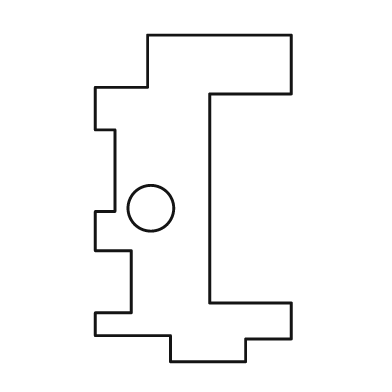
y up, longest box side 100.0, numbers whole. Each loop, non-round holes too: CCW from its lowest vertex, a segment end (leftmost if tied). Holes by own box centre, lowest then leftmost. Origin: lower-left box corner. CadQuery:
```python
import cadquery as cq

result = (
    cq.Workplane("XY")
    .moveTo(23.0, 0.0)
    .lineTo(46.0, 0.0)
    .lineTo(46.0, 7.0)
    .lineTo(60.0, 7.0)
    .lineTo(60.0, 18.0)
    .lineTo(35.0, 18.0)
    .lineTo(35.0, 82.0)
    .lineTo(60.0, 82.0)
    .lineTo(60.0, 100.0)
    .lineTo(16.0, 100.0)
    .lineTo(16.0, 84.0)
    .lineTo(0.0, 84.0)
    .lineTo(0.0, 71.0)
    .lineTo(6.0, 71.0)
    .lineTo(6.0, 46.0)
    .lineTo(0.0, 46.0)
    .lineTo(0.0, 34.0)
    .lineTo(11.0, 34.0)
    .lineTo(11.0, 15.0)
    .lineTo(0.0, 15.0)
    .lineTo(0.0, 8.0)
    .lineTo(23.0, 8.0)
    .close()
    .moveTo(17.0, 47.0)
    .circle(7.0)
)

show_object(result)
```